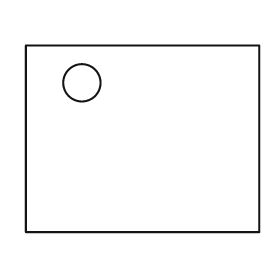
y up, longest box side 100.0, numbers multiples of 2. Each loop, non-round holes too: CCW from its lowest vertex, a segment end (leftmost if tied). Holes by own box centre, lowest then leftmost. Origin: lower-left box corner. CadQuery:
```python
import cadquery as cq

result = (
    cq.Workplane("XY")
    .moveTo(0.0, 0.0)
    .lineTo(100.0, 0.0)
    .lineTo(100.0, 80.0)
    .lineTo(0.0, 80.0)
    .close()
    .moveTo(24.0, 64.0)
    .circle(8.0)
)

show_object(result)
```